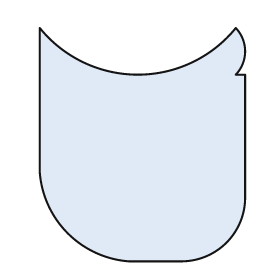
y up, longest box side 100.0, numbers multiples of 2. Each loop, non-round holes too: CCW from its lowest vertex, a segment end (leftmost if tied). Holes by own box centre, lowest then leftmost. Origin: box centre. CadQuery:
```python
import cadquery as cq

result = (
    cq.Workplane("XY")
    .moveTo(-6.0, -50.0)
    .lineTo(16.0, -50.0)
    .threePointArc((36.0, -42.0), (44.0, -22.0))
    .lineTo(44.0, 30.0)
    .lineTo(40.0, 30.0)
    .threePointArc((44.0, 40.0), (40.0, 50.0))
    .threePointArc((-2.0, 30.0), (-44.0, 50.0))
    .lineTo(-44.0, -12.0)
    .threePointArc((-32.0, -38.0), (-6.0, -50.0))
    .close()
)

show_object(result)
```